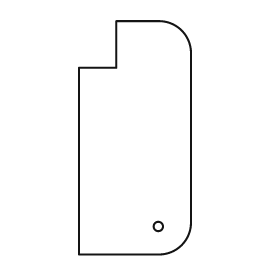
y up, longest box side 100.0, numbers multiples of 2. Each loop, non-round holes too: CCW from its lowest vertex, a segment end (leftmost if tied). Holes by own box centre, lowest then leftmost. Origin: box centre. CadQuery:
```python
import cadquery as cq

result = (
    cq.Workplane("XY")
    .moveTo(-24.0, -50.0)
    .lineTo(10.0, -50.0)
    .threePointArc((20.0, -46.0), (24.0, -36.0))
    .lineTo(24.0, 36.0)
    .threePointArc((20.0, 46.0), (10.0, 50.0))
    .lineTo(-8.0, 50.0)
    .lineTo(-8.0, 30.0)
    .lineTo(-24.0, 30.0)
    .close()
    .moveTo(10.0, -38.0)
    .circle(2.0)
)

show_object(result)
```